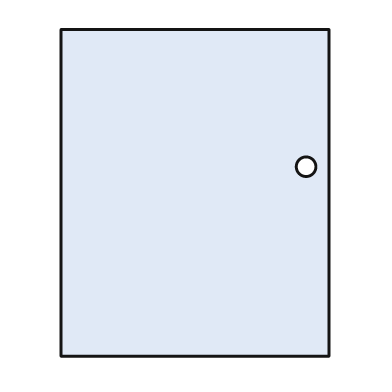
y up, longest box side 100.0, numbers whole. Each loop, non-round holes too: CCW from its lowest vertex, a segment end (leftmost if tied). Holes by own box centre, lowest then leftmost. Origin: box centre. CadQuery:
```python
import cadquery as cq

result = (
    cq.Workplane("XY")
    .moveTo(-41.0, -50.0)
    .lineTo(41.0, -50.0)
    .lineTo(41.0, 50.0)
    .lineTo(-41.0, 50.0)
    .close()
    .moveTo(34.0, 8.0)
    .circle(3.0)
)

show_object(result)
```